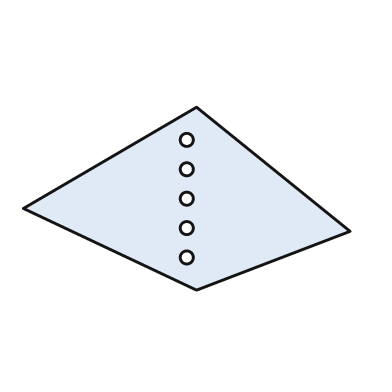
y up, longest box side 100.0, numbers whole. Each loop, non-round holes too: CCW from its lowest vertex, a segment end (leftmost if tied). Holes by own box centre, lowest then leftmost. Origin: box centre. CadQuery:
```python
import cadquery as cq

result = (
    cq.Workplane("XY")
    .moveTo(3.0, -28.0)
    .lineTo(50.0, -10.0)
    .lineTo(3.0, 28.0)
    .lineTo(-50.0, -3.0)
    .close()
    .moveTo(0.0, -18.0)
    .circle(2.0)
    .moveTo(0.0, -9.0)
    .circle(2.0)
    .moveTo(0.0, 0.0)
    .circle(2.0)
    .moveTo(0.0, 9.0)
    .circle(2.0)
    .moveTo(0.0, 18.0)
    .circle(2.0)
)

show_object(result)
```